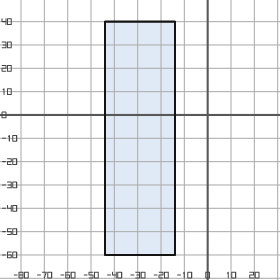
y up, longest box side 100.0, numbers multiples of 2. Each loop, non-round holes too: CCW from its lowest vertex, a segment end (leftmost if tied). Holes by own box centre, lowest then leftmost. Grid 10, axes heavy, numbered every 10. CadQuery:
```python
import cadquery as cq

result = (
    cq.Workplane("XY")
    .moveTo(-44.0, -60.0)
    .lineTo(-14.0, -60.0)
    .lineTo(-14.0, 40.0)
    .lineTo(-44.0, 40.0)
    .close()
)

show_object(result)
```